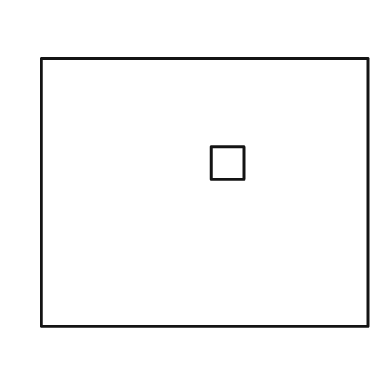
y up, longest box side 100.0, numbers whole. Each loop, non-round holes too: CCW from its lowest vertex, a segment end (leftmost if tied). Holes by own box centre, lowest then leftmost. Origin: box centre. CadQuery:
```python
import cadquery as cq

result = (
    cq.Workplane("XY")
    .moveTo(-50.0, -41.0)
    .lineTo(50.0, -41.0)
    .lineTo(50.0, 41.0)
    .lineTo(-50.0, 41.0)
    .close()
    .moveTo(2.0, 4.0)
    .lineTo(12.0, 4.0)
    .lineTo(12.0, 14.0)
    .lineTo(2.0, 14.0)
    .close()
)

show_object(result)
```